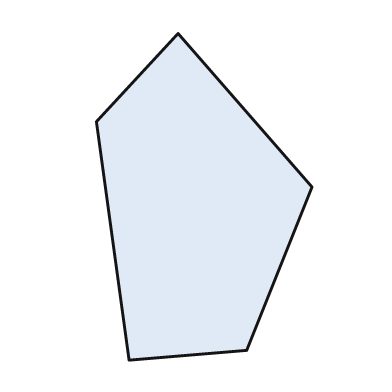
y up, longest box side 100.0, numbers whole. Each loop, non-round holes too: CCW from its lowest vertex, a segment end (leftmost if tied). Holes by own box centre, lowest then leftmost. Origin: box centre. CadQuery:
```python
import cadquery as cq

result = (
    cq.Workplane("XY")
    .moveTo(-23.0, -50.0)
    .lineTo(13.0, -47.0)
    .lineTo(33.0, 3.0)
    .lineTo(-8.0, 50.0)
    .lineTo(-33.0, 23.0)
    .close()
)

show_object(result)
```